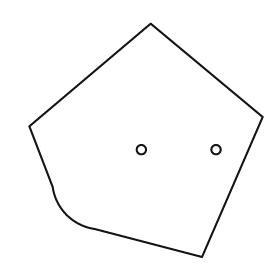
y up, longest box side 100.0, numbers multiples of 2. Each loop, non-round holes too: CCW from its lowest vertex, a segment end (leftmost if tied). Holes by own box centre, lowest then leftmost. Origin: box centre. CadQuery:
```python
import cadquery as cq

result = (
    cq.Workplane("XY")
    .moveTo(24.0, -50.0)
    .lineTo(50.0, 10.0)
    .lineTo(2.0, 50.0)
    .lineTo(-50.0, 6.0)
    .lineTo(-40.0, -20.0)
    .threePointArc((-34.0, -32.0), (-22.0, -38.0))
    .close()
    .moveTo(-2.0, -4.0)
    .circle(2.0)
    .moveTo(30.0, -4.0)
    .circle(2.0)
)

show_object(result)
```